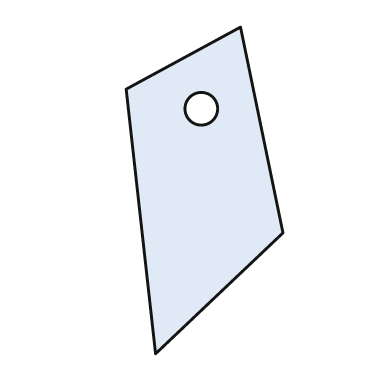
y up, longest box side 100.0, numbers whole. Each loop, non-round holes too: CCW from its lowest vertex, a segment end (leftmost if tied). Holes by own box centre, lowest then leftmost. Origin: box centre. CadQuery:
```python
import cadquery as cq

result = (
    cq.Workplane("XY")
    .moveTo(-15.0, -50.0)
    .lineTo(24.0, -13.0)
    .lineTo(11.0, 50.0)
    .lineTo(-24.0, 31.0)
    .close()
    .moveTo(-1.0, 25.0)
    .circle(5.0)
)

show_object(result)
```